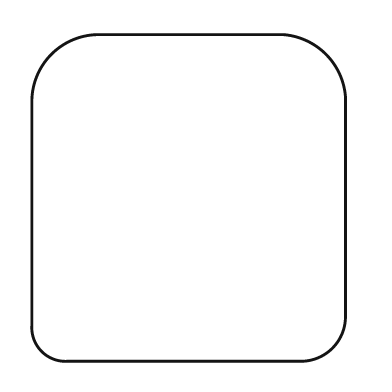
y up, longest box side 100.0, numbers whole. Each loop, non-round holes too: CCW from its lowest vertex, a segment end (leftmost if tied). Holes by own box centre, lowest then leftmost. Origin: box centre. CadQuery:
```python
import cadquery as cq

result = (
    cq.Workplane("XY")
    .moveTo(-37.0, -50.0)
    .lineTo(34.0, -50.0)
    .threePointArc((44.0, -46.0), (48.0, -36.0))
    .lineTo(48.0, 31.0)
    .threePointArc((42.0, 44.0), (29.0, 50.0))
    .lineTo(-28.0, 50.0)
    .threePointArc((-42.0, 44.0), (-48.0, 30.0))
    .lineTo(-48.0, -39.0)
    .threePointArc((-45.0, -47.0), (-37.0, -50.0))
    .close()
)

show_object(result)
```